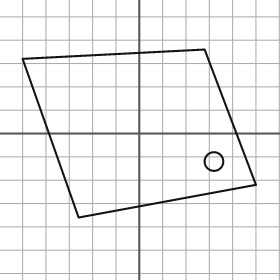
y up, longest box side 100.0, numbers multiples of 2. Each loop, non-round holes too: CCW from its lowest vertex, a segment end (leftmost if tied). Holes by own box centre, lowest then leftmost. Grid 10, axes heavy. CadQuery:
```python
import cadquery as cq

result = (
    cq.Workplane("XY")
    .moveTo(-26.0, -36.0)
    .lineTo(50.0, -22.0)
    .lineTo(28.0, 36.0)
    .lineTo(-50.0, 32.0)
    .close()
    .moveTo(32.0, -12.0)
    .circle(4.0)
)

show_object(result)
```